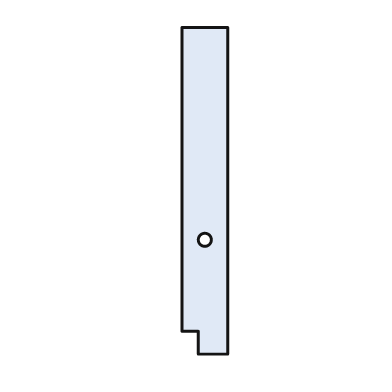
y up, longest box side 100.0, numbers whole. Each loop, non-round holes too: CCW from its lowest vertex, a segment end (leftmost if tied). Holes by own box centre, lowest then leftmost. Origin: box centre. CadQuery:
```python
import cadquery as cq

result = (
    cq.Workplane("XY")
    .moveTo(-2.0, -50.0)
    .lineTo(7.0, -50.0)
    .lineTo(7.0, 50.0)
    .lineTo(-7.0, 50.0)
    .lineTo(-7.0, -43.0)
    .lineTo(-2.0, -43.0)
    .close()
    .moveTo(0.0, -15.0)
    .circle(2.0)
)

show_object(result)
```